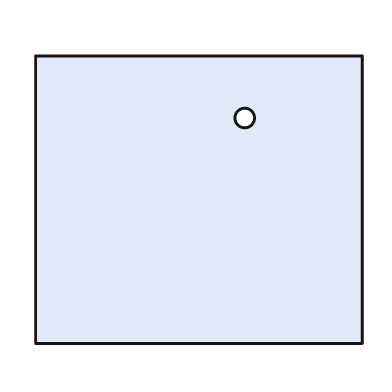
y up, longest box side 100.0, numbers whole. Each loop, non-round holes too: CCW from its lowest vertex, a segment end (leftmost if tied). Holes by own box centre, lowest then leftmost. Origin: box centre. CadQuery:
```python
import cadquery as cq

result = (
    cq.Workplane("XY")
    .moveTo(-50.0, -44.0)
    .lineTo(50.0, -44.0)
    .lineTo(50.0, 44.0)
    .lineTo(-50.0, 44.0)
    .close()
    .moveTo(14.0, 25.0)
    .circle(3.0)
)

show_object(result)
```